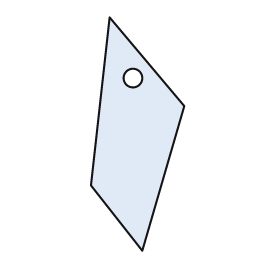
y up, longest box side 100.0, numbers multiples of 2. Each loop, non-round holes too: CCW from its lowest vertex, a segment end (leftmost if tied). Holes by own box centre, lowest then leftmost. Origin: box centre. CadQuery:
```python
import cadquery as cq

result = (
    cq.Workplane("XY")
    .moveTo(2.0, -50.0)
    .lineTo(20.0, 12.0)
    .lineTo(-12.0, 50.0)
    .lineTo(-20.0, -22.0)
    .close()
    .moveTo(-2.0, 24.0)
    .circle(4.0)
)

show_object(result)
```